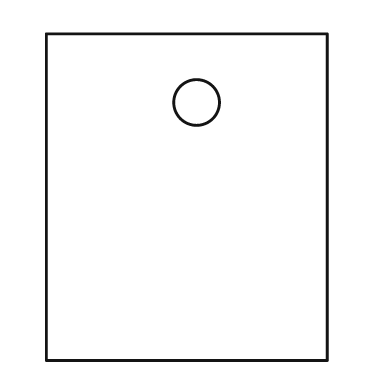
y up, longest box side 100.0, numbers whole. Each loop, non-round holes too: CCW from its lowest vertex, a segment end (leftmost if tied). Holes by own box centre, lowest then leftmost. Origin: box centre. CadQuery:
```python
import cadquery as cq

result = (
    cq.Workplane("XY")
    .moveTo(-43.0, -50.0)
    .lineTo(43.0, -50.0)
    .lineTo(43.0, 50.0)
    .lineTo(-43.0, 50.0)
    .close()
    .moveTo(3.0, 29.0)
    .circle(7.0)
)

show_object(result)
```